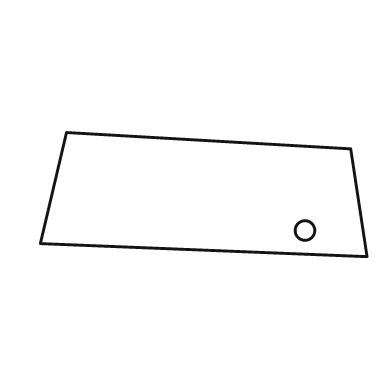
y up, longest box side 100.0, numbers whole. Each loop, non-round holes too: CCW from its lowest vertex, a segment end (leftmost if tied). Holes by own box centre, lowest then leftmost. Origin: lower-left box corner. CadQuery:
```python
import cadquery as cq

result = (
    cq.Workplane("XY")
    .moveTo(100.0, 0.0)
    .lineTo(95.0, 33.0)
    .lineTo(8.0, 38.0)
    .lineTo(0.0, 4.0)
    .close()
    .moveTo(81.0, 8.0)
    .circle(3.0)
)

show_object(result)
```